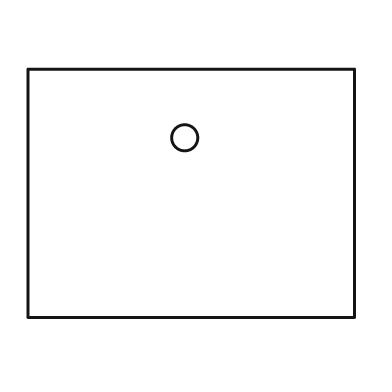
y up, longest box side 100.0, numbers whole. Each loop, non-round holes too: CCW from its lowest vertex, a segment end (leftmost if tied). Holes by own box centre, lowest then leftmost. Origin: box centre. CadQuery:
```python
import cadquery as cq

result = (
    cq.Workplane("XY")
    .moveTo(-50.0, -38.0)
    .lineTo(50.0, -38.0)
    .lineTo(50.0, 38.0)
    .lineTo(-50.0, 38.0)
    .close()
    .moveTo(-2.0, 17.0)
    .circle(4.0)
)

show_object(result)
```